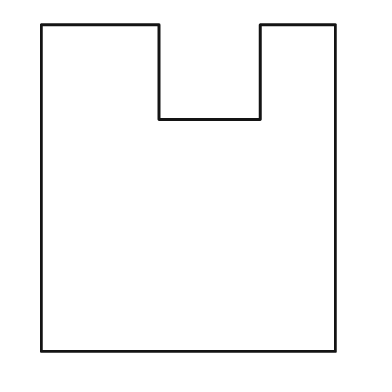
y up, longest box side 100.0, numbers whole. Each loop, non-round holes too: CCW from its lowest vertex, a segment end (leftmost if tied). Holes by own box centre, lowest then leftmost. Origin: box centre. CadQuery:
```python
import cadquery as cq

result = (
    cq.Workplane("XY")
    .moveTo(-45.0, -50.0)
    .lineTo(45.0, -50.0)
    .lineTo(45.0, 50.0)
    .lineTo(22.0, 50.0)
    .lineTo(22.0, 21.0)
    .lineTo(-9.0, 21.0)
    .lineTo(-9.0, 50.0)
    .lineTo(-45.0, 50.0)
    .close()
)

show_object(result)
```